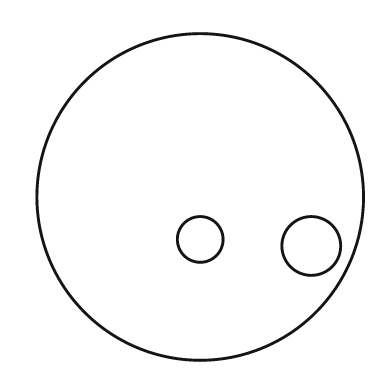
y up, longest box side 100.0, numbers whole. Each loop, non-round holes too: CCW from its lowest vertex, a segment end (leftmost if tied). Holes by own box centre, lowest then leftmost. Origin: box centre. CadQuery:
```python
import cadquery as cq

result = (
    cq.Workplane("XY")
    .moveTo(0.0, 0.0)
    .circle(50.0)
    .moveTo(34.0, -15.0)
    .circle(9.0)
    .moveTo(0.0, -13.0)
    .circle(7.0)
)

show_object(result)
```